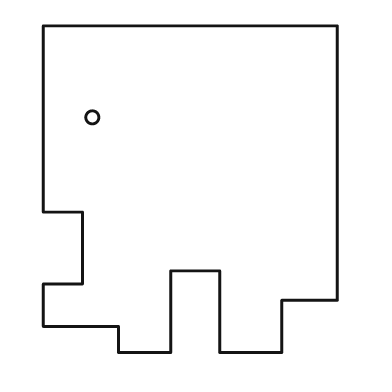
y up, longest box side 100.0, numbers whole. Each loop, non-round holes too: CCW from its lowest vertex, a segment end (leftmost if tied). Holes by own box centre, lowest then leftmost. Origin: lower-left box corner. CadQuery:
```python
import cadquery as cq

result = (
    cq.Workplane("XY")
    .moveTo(23.0, 0.0)
    .lineTo(39.0, 0.0)
    .lineTo(39.0, 25.0)
    .lineTo(54.0, 25.0)
    .lineTo(54.0, 0.0)
    .lineTo(73.0, 0.0)
    .lineTo(73.0, 16.0)
    .lineTo(90.0, 16.0)
    .lineTo(90.0, 100.0)
    .lineTo(0.0, 100.0)
    .lineTo(0.0, 43.0)
    .lineTo(12.0, 43.0)
    .lineTo(12.0, 21.0)
    .lineTo(0.0, 21.0)
    .lineTo(0.0, 8.0)
    .lineTo(23.0, 8.0)
    .close()
    .moveTo(15.0, 72.0)
    .circle(2.0)
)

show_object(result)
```